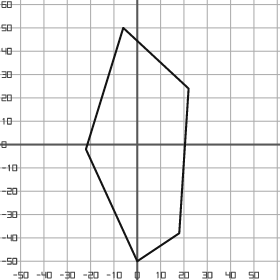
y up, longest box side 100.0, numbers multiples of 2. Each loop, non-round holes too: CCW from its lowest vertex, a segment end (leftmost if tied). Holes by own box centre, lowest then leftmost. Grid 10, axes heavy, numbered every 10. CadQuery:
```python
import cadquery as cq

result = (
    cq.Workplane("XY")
    .moveTo(0.0, -50.0)
    .lineTo(18.0, -38.0)
    .lineTo(22.0, 24.0)
    .lineTo(-6.0, 50.0)
    .lineTo(-22.0, -2.0)
    .close()
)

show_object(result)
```